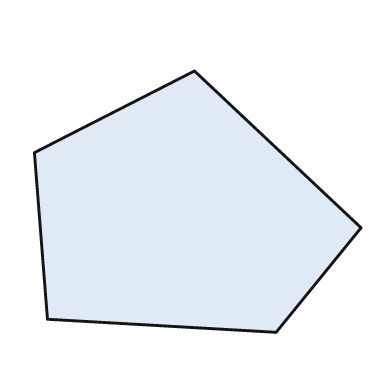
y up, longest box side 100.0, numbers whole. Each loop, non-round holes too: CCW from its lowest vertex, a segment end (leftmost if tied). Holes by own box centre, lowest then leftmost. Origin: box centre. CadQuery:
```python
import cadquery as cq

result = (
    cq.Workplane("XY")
    .moveTo(24.0, -40.0)
    .lineTo(50.0, -8.0)
    .lineTo(-1.0, 40.0)
    .lineTo(-50.0, 15.0)
    .lineTo(-46.0, -36.0)
    .close()
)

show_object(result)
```